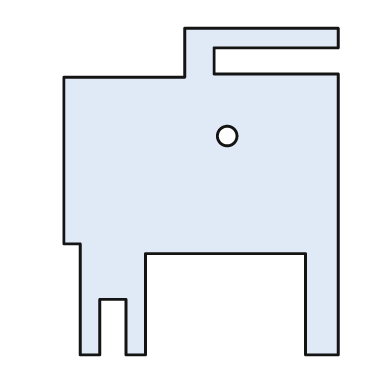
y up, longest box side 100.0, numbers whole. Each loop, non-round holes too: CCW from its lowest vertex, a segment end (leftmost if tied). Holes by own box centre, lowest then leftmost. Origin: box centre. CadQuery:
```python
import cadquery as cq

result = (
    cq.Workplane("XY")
    .moveTo(-37.0, -50.0)
    .lineTo(-31.0, -50.0)
    .lineTo(-31.0, -33.0)
    .lineTo(-23.0, -33.0)
    .lineTo(-23.0, -50.0)
    .lineTo(-17.0, -50.0)
    .lineTo(-17.0, -19.0)
    .lineTo(32.0, -19.0)
    .lineTo(32.0, -50.0)
    .lineTo(42.0, -50.0)
    .lineTo(42.0, 36.0)
    .lineTo(4.0, 36.0)
    .lineTo(4.0, 44.0)
    .lineTo(42.0, 44.0)
    .lineTo(42.0, 50.0)
    .lineTo(-5.0, 50.0)
    .lineTo(-5.0, 35.0)
    .lineTo(-42.0, 35.0)
    .lineTo(-42.0, -16.0)
    .lineTo(-37.0, -16.0)
    .close()
    .moveTo(8.0, 17.0)
    .circle(3.0)
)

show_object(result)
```